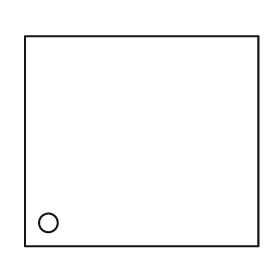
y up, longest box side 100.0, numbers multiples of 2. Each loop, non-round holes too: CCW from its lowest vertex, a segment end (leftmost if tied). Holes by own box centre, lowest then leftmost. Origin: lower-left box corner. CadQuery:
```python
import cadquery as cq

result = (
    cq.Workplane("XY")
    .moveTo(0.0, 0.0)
    .lineTo(100.0, 0.0)
    .lineTo(100.0, 90.0)
    .lineTo(0.0, 90.0)
    .close()
    .moveTo(10.0, 10.0)
    .circle(4.0)
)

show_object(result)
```